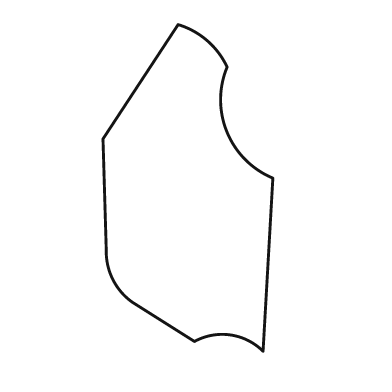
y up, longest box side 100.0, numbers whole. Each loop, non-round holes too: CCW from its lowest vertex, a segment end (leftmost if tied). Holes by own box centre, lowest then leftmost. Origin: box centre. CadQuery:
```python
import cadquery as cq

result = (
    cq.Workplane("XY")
    .moveTo(23.0, -50.0)
    .lineTo(26.0, 3.0)
    .threePointArc((12.0, 17.0), (12.0, 37.0))
    .threePointArc((6.0, 45.0), (-3.0, 50.0))
    .lineTo(-26.0, 15.0)
    .lineTo(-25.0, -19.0)
    .threePointArc((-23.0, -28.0), (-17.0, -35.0))
    .lineTo(2.0, -47.0)
    .threePointArc((13.0, -45.0), (23.0, -50.0))
    .close()
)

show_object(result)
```